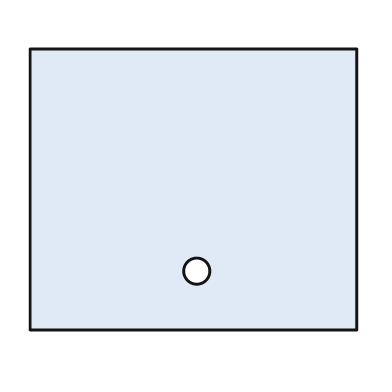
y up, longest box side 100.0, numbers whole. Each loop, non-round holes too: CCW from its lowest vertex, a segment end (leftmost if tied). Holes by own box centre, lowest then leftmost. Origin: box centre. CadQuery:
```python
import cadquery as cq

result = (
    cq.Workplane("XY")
    .moveTo(-50.0, -43.0)
    .lineTo(50.0, -43.0)
    .lineTo(50.0, 43.0)
    .lineTo(-50.0, 43.0)
    .close()
    .moveTo(1.0, -25.0)
    .circle(4.0)
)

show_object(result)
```